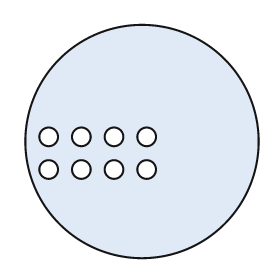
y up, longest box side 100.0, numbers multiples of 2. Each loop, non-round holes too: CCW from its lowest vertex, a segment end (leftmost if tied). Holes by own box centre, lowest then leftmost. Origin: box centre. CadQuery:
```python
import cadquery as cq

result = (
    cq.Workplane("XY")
    .moveTo(0.0, 0.0)
    .circle(50.0)
    .moveTo(-40.0, -12.0)
    .circle(4.0)
    .moveTo(-26.0, -12.0)
    .circle(4.0)
    .moveTo(-12.0, -12.0)
    .circle(4.0)
    .moveTo(2.0, -12.0)
    .circle(4.0)
    .moveTo(-40.0, 2.0)
    .circle(4.0)
    .moveTo(-26.0, 2.0)
    .circle(4.0)
    .moveTo(-12.0, 2.0)
    .circle(4.0)
    .moveTo(2.0, 2.0)
    .circle(4.0)
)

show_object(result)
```